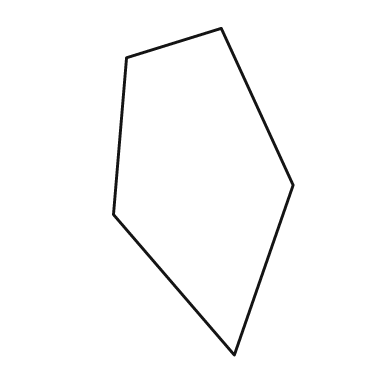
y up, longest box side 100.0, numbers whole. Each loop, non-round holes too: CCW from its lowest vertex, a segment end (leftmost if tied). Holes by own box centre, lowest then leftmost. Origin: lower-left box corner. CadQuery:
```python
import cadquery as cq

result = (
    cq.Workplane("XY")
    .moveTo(37.0, 0.0)
    .lineTo(55.0, 52.0)
    .lineTo(33.0, 100.0)
    .lineTo(4.0, 91.0)
    .lineTo(0.0, 43.0)
    .close()
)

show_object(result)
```